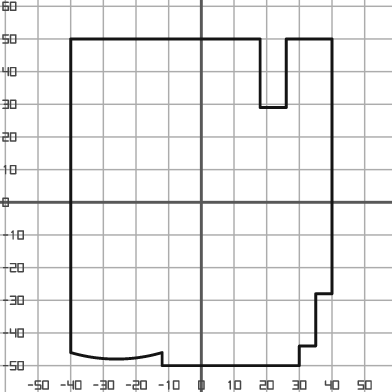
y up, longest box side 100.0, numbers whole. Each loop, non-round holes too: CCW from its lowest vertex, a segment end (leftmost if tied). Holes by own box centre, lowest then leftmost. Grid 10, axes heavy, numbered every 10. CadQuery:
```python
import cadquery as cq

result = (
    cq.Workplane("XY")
    .moveTo(-12.0, -50.0)
    .lineTo(30.0, -50.0)
    .lineTo(30.0, -44.0)
    .lineTo(35.0, -44.0)
    .lineTo(35.0, -28.0)
    .lineTo(40.0, -28.0)
    .lineTo(40.0, 50.0)
    .lineTo(26.0, 50.0)
    .lineTo(26.0, 29.0)
    .lineTo(18.0, 29.0)
    .lineTo(18.0, 50.0)
    .lineTo(-40.0, 50.0)
    .lineTo(-40.0, -46.0)
    .threePointArc((-26.0, -48.0), (-12.0, -46.0))
    .close()
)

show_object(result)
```